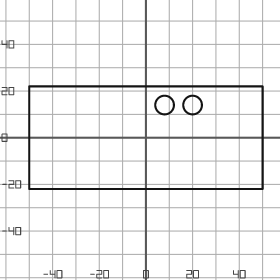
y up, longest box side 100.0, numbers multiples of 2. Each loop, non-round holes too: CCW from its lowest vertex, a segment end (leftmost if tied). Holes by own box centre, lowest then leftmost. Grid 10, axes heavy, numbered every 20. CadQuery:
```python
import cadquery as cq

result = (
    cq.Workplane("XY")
    .moveTo(-50.0, -22.0)
    .lineTo(50.0, -22.0)
    .lineTo(50.0, 22.0)
    .lineTo(-50.0, 22.0)
    .close()
    .moveTo(8.0, 14.0)
    .circle(4.0)
    .moveTo(20.0, 14.0)
    .circle(4.0)
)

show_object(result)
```